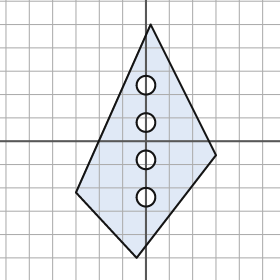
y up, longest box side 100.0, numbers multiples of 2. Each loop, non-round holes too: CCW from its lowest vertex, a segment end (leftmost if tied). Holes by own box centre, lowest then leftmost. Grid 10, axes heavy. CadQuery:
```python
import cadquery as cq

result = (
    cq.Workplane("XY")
    .moveTo(-4.0, -50.0)
    .lineTo(30.0, -6.0)
    .lineTo(2.0, 50.0)
    .lineTo(-30.0, -22.0)
    .close()
    .moveTo(0.0, -24.0)
    .circle(4.0)
    .moveTo(0.0, -8.0)
    .circle(4.0)
    .moveTo(0.0, 8.0)
    .circle(4.0)
    .moveTo(0.0, 24.0)
    .circle(4.0)
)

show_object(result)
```